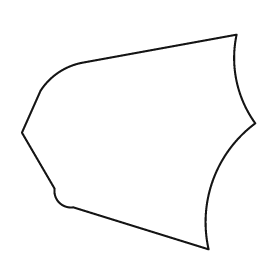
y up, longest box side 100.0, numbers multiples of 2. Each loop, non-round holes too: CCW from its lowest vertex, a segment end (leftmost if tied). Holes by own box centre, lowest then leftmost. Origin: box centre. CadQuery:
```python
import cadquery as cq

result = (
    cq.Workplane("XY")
    .moveTo(30.0, -46.0)
    .threePointArc((32.0, -16.0), (50.0, 8.0))
    .threePointArc((42.0, 26.0), (42.0, 46.0))
    .lineTo(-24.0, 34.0)
    .threePointArc((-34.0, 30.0), (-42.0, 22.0))
    .lineTo(-50.0, 4.0)
    .lineTo(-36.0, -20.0)
    .threePointArc((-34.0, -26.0), (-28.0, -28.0))
    .close()
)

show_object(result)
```